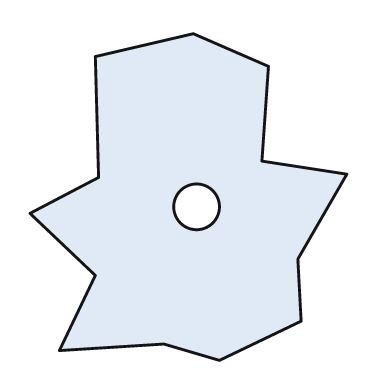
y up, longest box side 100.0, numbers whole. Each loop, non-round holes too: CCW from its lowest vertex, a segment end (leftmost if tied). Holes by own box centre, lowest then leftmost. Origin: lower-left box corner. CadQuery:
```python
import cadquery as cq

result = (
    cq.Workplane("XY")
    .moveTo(58.0, 0.0)
    .lineTo(83.0, 12.0)
    .lineTo(82.0, 31.0)
    .lineTo(97.0, 57.0)
    .lineTo(71.0, 61.0)
    .lineTo(73.0, 90.0)
    .lineTo(50.0, 100.0)
    .lineTo(20.0, 93.0)
    .lineTo(21.0, 56.0)
    .lineTo(0.0, 45.0)
    .lineTo(20.0, 26.0)
    .lineTo(9.0, 3.0)
    .lineTo(41.0, 5.0)
    .close()
    .moveTo(51.0, 47.0)
    .circle(7.0)
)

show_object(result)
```